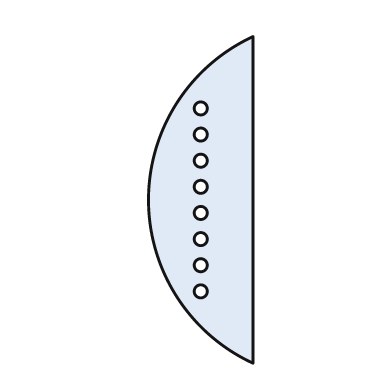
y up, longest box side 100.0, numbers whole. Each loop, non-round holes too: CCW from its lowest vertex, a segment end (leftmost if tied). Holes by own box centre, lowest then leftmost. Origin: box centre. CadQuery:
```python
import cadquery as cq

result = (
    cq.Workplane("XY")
    .moveTo(16.0, -50.0)
    .lineTo(16.0, 50.0)
    .threePointArc((-16.0, 0.0), (16.0, -50.0))
    .close()
    .moveTo(0.0, -28.0)
    .circle(2.0)
    .moveTo(0.0, -20.0)
    .circle(2.0)
    .moveTo(0.0, -12.0)
    .circle(2.0)
    .moveTo(0.0, -4.0)
    .circle(2.0)
    .moveTo(0.0, 4.0)
    .circle(2.0)
    .moveTo(0.0, 12.0)
    .circle(2.0)
    .moveTo(0.0, 20.0)
    .circle(2.0)
    .moveTo(0.0, 28.0)
    .circle(2.0)
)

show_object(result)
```